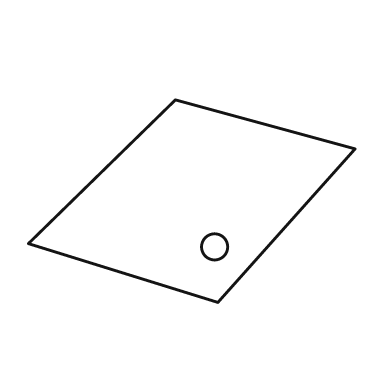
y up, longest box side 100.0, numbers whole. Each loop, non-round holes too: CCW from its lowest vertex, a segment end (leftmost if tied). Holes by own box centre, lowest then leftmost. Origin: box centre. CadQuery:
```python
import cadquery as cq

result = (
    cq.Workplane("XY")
    .moveTo(8.0, -31.0)
    .lineTo(50.0, 16.0)
    .lineTo(-5.0, 31.0)
    .lineTo(-50.0, -13.0)
    .close()
    .moveTo(7.0, -14.0)
    .circle(4.0)
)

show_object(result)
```